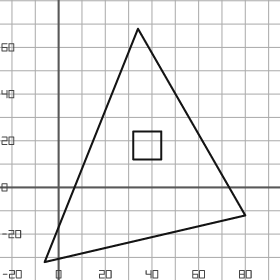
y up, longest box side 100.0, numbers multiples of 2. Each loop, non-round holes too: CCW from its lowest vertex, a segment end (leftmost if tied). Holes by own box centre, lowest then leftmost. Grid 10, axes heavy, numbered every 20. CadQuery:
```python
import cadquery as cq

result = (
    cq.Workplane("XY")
    .moveTo(-6.0, -32.0)
    .lineTo(80.0, -12.0)
    .lineTo(34.0, 68.0)
    .close()
    .moveTo(32.0, 12.0)
    .lineTo(44.0, 12.0)
    .lineTo(44.0, 24.0)
    .lineTo(32.0, 24.0)
    .close()
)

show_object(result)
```